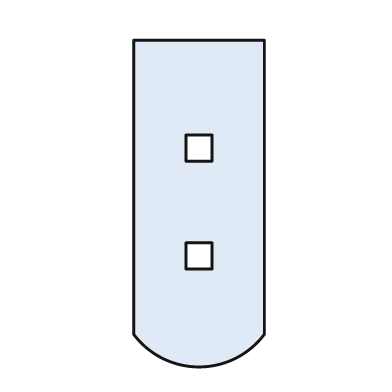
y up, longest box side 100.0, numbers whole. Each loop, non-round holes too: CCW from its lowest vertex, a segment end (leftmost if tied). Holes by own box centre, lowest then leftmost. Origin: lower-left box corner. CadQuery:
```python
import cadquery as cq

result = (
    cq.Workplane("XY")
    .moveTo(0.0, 10.0)
    .threePointArc((20.0, 0.0), (40.0, 10.0))
    .lineTo(40.0, 100.0)
    .lineTo(0.0, 100.0)
    .close()
    .moveTo(16.0, 30.0)
    .lineTo(24.0, 30.0)
    .lineTo(24.0, 38.0)
    .lineTo(16.0, 38.0)
    .close()
    .moveTo(16.0, 63.0)
    .lineTo(24.0, 63.0)
    .lineTo(24.0, 71.0)
    .lineTo(16.0, 71.0)
    .close()
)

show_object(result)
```